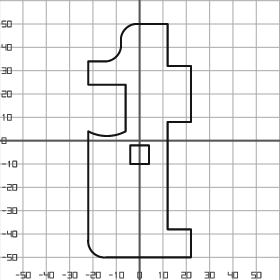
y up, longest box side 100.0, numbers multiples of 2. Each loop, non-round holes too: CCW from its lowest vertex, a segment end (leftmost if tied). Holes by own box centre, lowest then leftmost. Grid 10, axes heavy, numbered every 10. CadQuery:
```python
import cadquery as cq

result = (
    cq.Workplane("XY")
    .moveTo(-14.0, -50.0)
    .lineTo(22.0, -50.0)
    .lineTo(22.0, -38.0)
    .lineTo(12.0, -38.0)
    .lineTo(12.0, 8.0)
    .lineTo(22.0, 8.0)
    .lineTo(22.0, 32.0)
    .lineTo(12.0, 32.0)
    .lineTo(12.0, 50.0)
    .lineTo(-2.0, 50.0)
    .threePointArc((-6.0, 48.0), (-8.0, 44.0))
    .lineTo(-8.0, 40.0)
    .threePointArc((-10.0, 36.0), (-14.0, 34.0))
    .lineTo(-22.0, 34.0)
    .lineTo(-22.0, 24.0)
    .lineTo(-6.0, 24.0)
    .lineTo(-6.0, 4.0)
    .threePointArc((-14.0, 2.0), (-22.0, 4.0))
    .lineTo(-22.0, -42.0)
    .threePointArc((-20.0, -48.0), (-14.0, -50.0))
    .close()
    .moveTo(-4.0, -10.0)
    .lineTo(4.0, -10.0)
    .lineTo(4.0, -2.0)
    .lineTo(-4.0, -2.0)
    .close()
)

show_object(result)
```